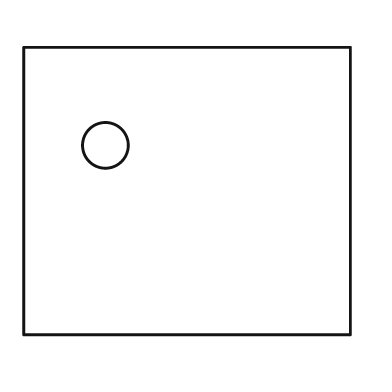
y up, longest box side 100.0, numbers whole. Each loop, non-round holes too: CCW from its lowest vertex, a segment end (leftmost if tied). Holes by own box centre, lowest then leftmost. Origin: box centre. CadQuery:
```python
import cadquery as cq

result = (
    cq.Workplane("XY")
    .moveTo(-50.0, -44.0)
    .lineTo(50.0, -44.0)
    .lineTo(50.0, 44.0)
    .lineTo(-50.0, 44.0)
    .close()
    .moveTo(-25.0, 14.0)
    .circle(7.0)
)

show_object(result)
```